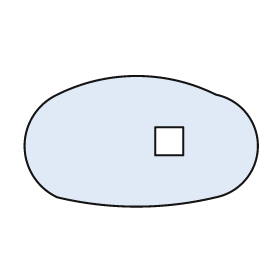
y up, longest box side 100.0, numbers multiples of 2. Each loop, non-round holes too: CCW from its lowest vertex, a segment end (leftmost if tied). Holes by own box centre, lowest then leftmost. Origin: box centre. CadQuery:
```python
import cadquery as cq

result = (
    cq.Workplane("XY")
    .moveTo(-36.0, -24.0)
    .threePointArc((-2.0, -28.0), (32.0, -24.0))
    .threePointArc((50.0, -2.0), (32.0, 20.0))
    .threePointArc((-2.0, 28.0), (-36.0, 20.0))
    .threePointArc((-50.0, -2.0), (-36.0, -24.0))
    .close()
    .moveTo(6.0, -6.0)
    .lineTo(18.0, -6.0)
    .lineTo(18.0, 6.0)
    .lineTo(6.0, 6.0)
    .close()
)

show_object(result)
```